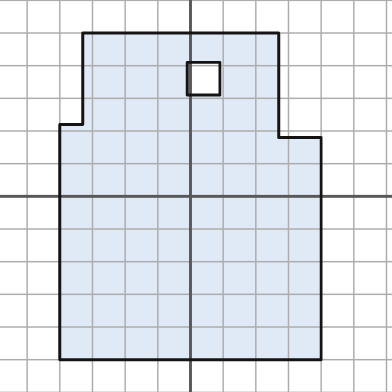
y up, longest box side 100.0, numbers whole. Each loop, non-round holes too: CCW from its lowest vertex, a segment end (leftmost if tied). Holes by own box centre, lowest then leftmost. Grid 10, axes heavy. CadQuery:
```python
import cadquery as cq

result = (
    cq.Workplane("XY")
    .moveTo(-40.0, -50.0)
    .lineTo(40.0, -50.0)
    .lineTo(40.0, 18.0)
    .lineTo(27.0, 18.0)
    .lineTo(27.0, 50.0)
    .lineTo(-33.0, 50.0)
    .lineTo(-33.0, 22.0)
    .lineTo(-40.0, 22.0)
    .close()
    .moveTo(-1.0, 31.0)
    .lineTo(9.0, 31.0)
    .lineTo(9.0, 41.0)
    .lineTo(-1.0, 41.0)
    .close()
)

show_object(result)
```